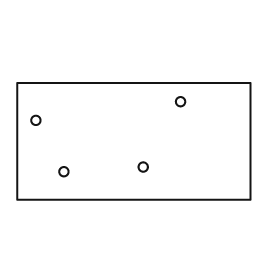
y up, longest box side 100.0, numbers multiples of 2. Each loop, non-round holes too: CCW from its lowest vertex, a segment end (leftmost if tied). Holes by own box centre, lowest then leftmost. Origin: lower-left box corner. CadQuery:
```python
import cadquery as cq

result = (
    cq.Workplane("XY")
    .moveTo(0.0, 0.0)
    .lineTo(100.0, 0.0)
    .lineTo(100.0, 50.0)
    .lineTo(0.0, 50.0)
    .close()
    .moveTo(20.0, 12.0)
    .circle(2.0)
    .moveTo(54.0, 14.0)
    .circle(2.0)
    .moveTo(8.0, 34.0)
    .circle(2.0)
    .moveTo(70.0, 42.0)
    .circle(2.0)
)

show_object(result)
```